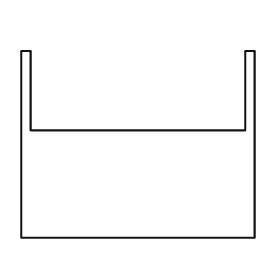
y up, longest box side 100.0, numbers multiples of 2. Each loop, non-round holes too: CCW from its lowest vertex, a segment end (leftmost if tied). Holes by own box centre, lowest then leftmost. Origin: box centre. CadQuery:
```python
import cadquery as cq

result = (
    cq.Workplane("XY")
    .moveTo(-50.0, -40.0)
    .lineTo(50.0, -40.0)
    .lineTo(50.0, 40.0)
    .lineTo(46.0, 40.0)
    .lineTo(46.0, 6.0)
    .lineTo(-46.0, 6.0)
    .lineTo(-46.0, 40.0)
    .lineTo(-50.0, 40.0)
    .close()
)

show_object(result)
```